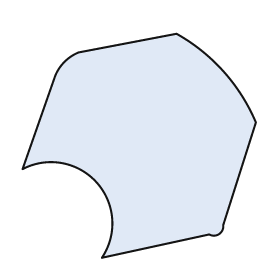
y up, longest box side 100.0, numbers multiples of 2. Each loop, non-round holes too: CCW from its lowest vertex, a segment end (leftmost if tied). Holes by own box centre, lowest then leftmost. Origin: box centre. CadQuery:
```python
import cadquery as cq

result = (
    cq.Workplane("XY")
    .moveTo(-16.0, -48.0)
    .lineTo(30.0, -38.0)
    .threePointArc((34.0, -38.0), (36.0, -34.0))
    .lineTo(50.0, 10.0)
    .threePointArc((36.0, 32.0), (16.0, 48.0))
    .lineTo(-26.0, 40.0)
    .threePointArc((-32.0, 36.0), (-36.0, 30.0))
    .lineTo(-50.0, -10.0)
    .threePointArc((-18.0, -16.0), (-16.0, -48.0))
    .close()
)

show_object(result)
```